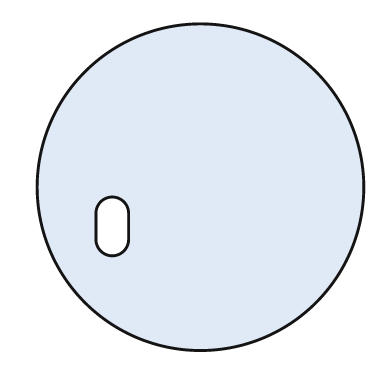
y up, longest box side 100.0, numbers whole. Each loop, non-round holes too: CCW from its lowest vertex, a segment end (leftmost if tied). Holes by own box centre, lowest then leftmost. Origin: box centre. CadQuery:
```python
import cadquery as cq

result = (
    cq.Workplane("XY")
    .moveTo(0.0, 0.0)
    .circle(50.0)
    .moveTo(-32.0, -16.0)
    .threePointArc((-27.0, -21.0), (-22.0, -16.0))
    .lineTo(-22.0, -8.0)
    .threePointArc((-27.0, -3.0), (-32.0, -8.0))
    .close()
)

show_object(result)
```